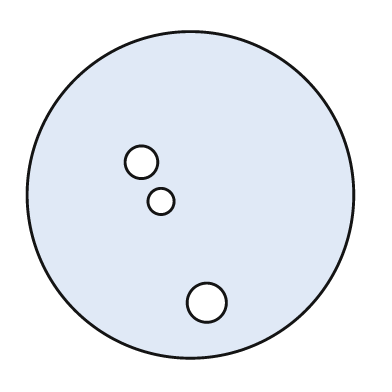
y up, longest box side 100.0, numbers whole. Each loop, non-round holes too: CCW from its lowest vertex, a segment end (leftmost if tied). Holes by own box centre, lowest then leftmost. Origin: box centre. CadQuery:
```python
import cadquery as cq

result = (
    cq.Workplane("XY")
    .moveTo(0.0, 0.0)
    .circle(50.0)
    .moveTo(5.0, -33.0)
    .circle(6.0)
    .moveTo(-9.0, -2.0)
    .circle(4.0)
    .moveTo(-15.0, 10.0)
    .circle(5.0)
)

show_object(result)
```